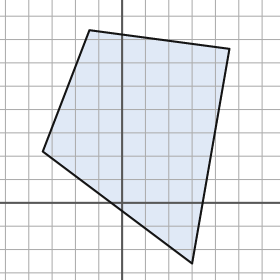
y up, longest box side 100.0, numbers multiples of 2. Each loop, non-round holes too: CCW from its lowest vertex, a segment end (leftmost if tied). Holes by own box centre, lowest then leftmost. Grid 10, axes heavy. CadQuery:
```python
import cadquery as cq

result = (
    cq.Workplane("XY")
    .moveTo(30.0, -26.0)
    .lineTo(46.0, 66.0)
    .lineTo(-14.0, 74.0)
    .lineTo(-34.0, 22.0)
    .close()
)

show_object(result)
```